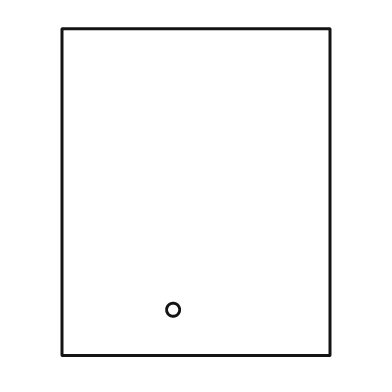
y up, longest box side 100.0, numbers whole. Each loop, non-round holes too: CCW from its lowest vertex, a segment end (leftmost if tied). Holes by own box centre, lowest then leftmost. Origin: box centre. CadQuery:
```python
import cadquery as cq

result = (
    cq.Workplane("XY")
    .moveTo(-41.0, -50.0)
    .lineTo(41.0, -50.0)
    .lineTo(41.0, 50.0)
    .lineTo(-41.0, 50.0)
    .close()
    .moveTo(-7.0, -36.0)
    .circle(2.0)
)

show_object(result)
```